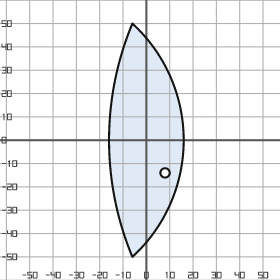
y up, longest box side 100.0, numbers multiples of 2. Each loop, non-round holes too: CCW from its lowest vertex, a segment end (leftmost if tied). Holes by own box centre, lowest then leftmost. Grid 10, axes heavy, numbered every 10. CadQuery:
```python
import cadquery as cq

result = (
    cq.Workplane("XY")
    .moveTo(-6.0, -50.0)
    .threePointArc((16.0, 0.0), (-6.0, 50.0))
    .threePointArc((-16.0, 0.0), (-6.0, -50.0))
    .close()
    .moveTo(8.0, -14.0)
    .circle(2.0)
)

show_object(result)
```